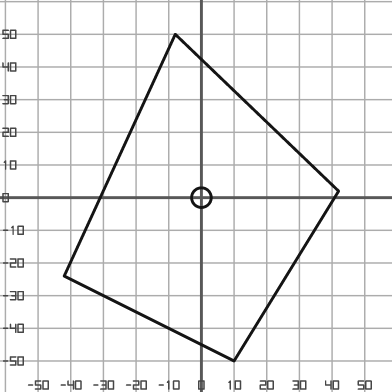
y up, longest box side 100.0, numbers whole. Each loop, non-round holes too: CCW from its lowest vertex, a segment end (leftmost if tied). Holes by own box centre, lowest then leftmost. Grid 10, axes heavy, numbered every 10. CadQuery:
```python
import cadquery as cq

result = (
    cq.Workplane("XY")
    .moveTo(10.0, -50.0)
    .lineTo(42.0, 2.0)
    .lineTo(-8.0, 50.0)
    .lineTo(-42.0, -24.0)
    .close()
    .moveTo(0.0, 0.0)
    .circle(3.0)
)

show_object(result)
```